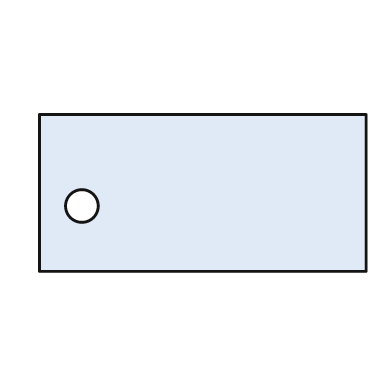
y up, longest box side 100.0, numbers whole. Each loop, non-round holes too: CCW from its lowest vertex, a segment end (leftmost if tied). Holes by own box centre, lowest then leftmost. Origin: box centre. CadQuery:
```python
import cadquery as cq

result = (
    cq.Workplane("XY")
    .moveTo(-50.0, -24.0)
    .lineTo(50.0, -24.0)
    .lineTo(50.0, 24.0)
    .lineTo(-50.0, 24.0)
    .close()
    .moveTo(-37.0, -4.0)
    .circle(5.0)
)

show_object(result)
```